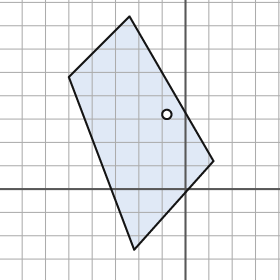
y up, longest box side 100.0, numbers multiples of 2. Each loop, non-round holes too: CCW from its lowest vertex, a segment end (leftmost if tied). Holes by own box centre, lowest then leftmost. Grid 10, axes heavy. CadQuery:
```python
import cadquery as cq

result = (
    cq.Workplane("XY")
    .moveTo(-22.0, -26.0)
    .lineTo(12.0, 12.0)
    .lineTo(-24.0, 74.0)
    .lineTo(-50.0, 48.0)
    .close()
    .moveTo(-8.0, 32.0)
    .circle(2.0)
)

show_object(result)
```